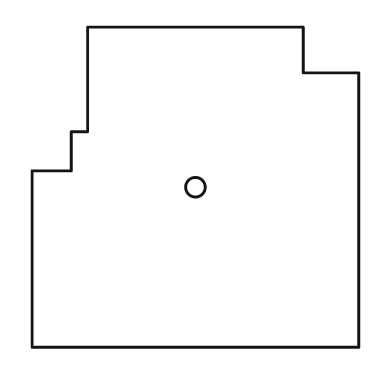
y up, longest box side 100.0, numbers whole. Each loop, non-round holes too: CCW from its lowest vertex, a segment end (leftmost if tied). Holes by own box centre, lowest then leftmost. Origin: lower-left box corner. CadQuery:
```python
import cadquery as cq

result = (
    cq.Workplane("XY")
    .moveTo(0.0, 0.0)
    .lineTo(100.0, 0.0)
    .lineTo(100.0, 84.0)
    .lineTo(83.0, 84.0)
    .lineTo(83.0, 98.0)
    .lineTo(17.0, 98.0)
    .lineTo(17.0, 66.0)
    .lineTo(12.0, 66.0)
    .lineTo(12.0, 54.0)
    .lineTo(0.0, 54.0)
    .close()
    .moveTo(50.0, 49.0)
    .circle(3.0)
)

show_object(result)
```